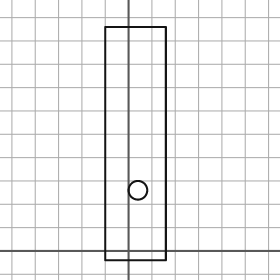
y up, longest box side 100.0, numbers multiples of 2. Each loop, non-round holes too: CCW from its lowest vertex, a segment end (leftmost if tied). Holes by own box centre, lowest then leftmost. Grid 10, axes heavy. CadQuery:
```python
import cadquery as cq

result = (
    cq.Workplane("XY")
    .moveTo(-10.0, -4.0)
    .lineTo(16.0, -4.0)
    .lineTo(16.0, 96.0)
    .lineTo(-10.0, 96.0)
    .close()
    .moveTo(4.0, 26.0)
    .circle(4.0)
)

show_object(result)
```